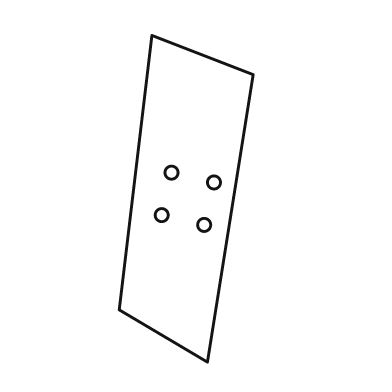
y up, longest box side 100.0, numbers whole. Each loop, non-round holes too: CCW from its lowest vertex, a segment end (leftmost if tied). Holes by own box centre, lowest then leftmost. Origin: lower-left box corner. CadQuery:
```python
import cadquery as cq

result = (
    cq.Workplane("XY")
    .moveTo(27.0, 0.0)
    .lineTo(41.0, 88.0)
    .lineTo(10.0, 100.0)
    .lineTo(0.0, 16.0)
    .close()
    .moveTo(26.0, 42.0)
    .circle(2.0)
    .moveTo(13.0, 45.0)
    .circle(2.0)
    .moveTo(29.0, 55.0)
    .circle(2.0)
    .moveTo(16.0, 58.0)
    .circle(2.0)
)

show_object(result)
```